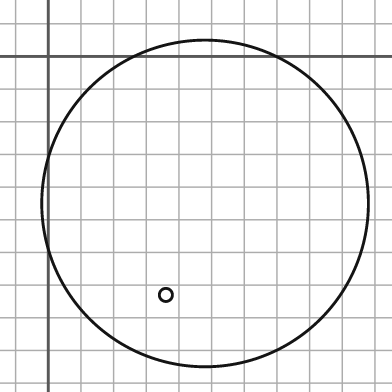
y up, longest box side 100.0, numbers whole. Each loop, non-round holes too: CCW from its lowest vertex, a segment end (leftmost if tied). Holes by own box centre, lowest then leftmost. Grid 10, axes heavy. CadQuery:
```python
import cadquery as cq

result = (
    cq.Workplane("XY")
    .moveTo(48.0, -45.0)
    .circle(50.0)
    .moveTo(36.0, -73.0)
    .circle(2.0)
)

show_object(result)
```